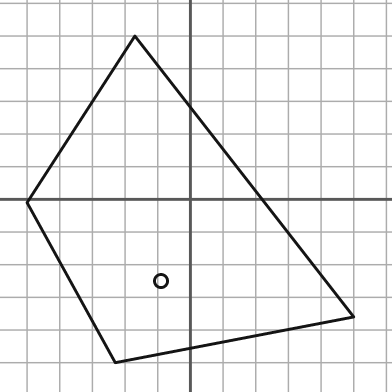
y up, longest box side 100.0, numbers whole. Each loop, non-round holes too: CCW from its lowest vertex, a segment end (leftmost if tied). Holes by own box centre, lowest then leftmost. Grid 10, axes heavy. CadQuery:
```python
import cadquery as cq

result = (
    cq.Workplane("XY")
    .moveTo(-23.0, -50.0)
    .lineTo(50.0, -36.0)
    .lineTo(-17.0, 50.0)
    .lineTo(-50.0, -1.0)
    .close()
    .moveTo(-9.0, -25.0)
    .circle(2.0)
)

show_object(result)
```